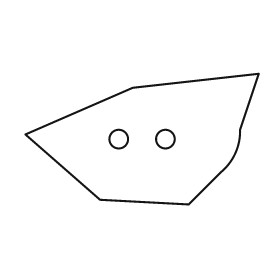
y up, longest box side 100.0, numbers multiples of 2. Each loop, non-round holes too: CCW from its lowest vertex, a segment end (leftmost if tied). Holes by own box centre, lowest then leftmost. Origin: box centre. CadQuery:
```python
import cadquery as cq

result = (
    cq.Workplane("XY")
    .moveTo(20.0, -28.0)
    .lineTo(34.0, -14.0)
    .threePointArc((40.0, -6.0), (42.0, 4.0))
    .lineTo(50.0, 28.0)
    .lineTo(-4.0, 22.0)
    .lineTo(-50.0, 2.0)
    .lineTo(-18.0, -26.0)
    .close()
    .moveTo(-10.0, 0.0)
    .circle(4.0)
    .moveTo(10.0, 0.0)
    .circle(4.0)
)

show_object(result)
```